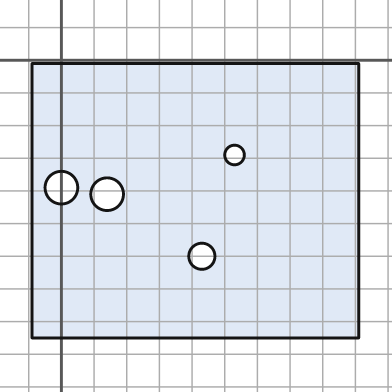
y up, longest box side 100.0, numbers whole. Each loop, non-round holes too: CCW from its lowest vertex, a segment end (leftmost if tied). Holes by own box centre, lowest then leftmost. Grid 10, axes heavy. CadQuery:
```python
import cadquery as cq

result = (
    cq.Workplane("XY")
    .moveTo(-9.0, -85.0)
    .lineTo(91.0, -85.0)
    .lineTo(91.0, -1.0)
    .lineTo(-9.0, -1.0)
    .close()
    .moveTo(43.0, -60.0)
    .circle(4.0)
    .moveTo(14.0, -41.0)
    .circle(5.0)
    .moveTo(0.0, -39.0)
    .circle(5.0)
    .moveTo(53.0, -29.0)
    .circle(3.0)
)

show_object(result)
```